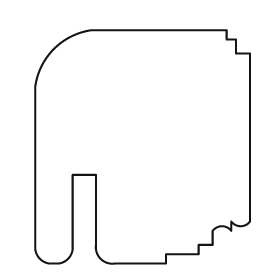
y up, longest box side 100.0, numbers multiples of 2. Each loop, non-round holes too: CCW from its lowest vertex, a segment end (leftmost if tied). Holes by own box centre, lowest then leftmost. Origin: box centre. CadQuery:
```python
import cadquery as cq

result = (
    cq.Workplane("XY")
    .moveTo(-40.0, -50.0)
    .lineTo(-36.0, -50.0)
    .threePointArc((-32.0, -48.0), (-30.0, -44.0))
    .lineTo(-30.0, -12.0)
    .lineTo(-20.0, -12.0)
    .lineTo(-20.0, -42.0)
    .threePointArc((-18.0, -48.0), (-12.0, -50.0))
    .lineTo(10.0, -50.0)
    .lineTo(10.0, -46.0)
    .lineTo(24.0, -46.0)
    .lineTo(24.0, -42.0)
    .lineTo(30.0, -42.0)
    .lineTo(30.0, -36.0)
    .threePointArc((34.0, -34.0), (38.0, -36.0))
    .lineTo(38.0, -32.0)
    .threePointArc((42.0, -34.0), (46.0, -32.0))
    .lineTo(46.0, 40.0)
    .lineTo(40.0, 40.0)
    .lineTo(40.0, 46.0)
    .lineTo(36.0, 46.0)
    .lineTo(36.0, 50.0)
    .lineTo(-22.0, 50.0)
    .threePointArc((-38.0, 42.0), (-46.0, 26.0))
    .lineTo(-46.0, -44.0)
    .threePointArc((-44.0, -48.0), (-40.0, -50.0))
    .close()
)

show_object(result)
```